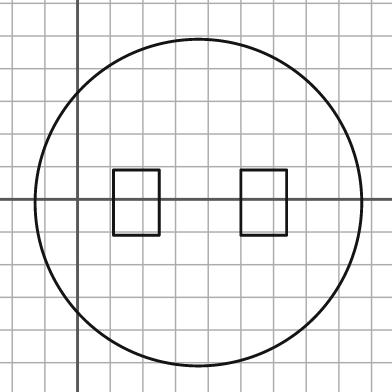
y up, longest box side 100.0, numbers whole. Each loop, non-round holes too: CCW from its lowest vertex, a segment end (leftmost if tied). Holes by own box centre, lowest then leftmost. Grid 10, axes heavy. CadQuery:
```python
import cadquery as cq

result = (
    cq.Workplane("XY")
    .moveTo(37.0, -1.0)
    .circle(50.0)
    .moveTo(11.0, -11.0)
    .lineTo(25.0, -11.0)
    .lineTo(25.0, 9.0)
    .lineTo(11.0, 9.0)
    .close()
    .moveTo(50.0, -11.0)
    .lineTo(64.0, -11.0)
    .lineTo(64.0, 9.0)
    .lineTo(50.0, 9.0)
    .close()
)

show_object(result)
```